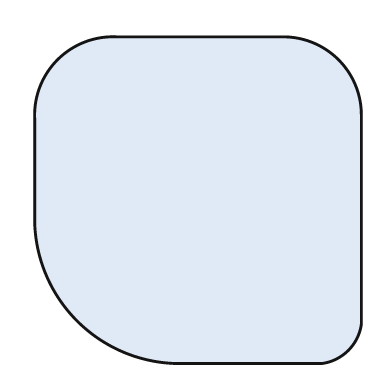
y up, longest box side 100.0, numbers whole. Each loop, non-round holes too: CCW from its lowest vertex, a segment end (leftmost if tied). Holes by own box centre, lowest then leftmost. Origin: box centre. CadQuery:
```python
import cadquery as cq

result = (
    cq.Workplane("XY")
    .moveTo(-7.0, -50.0)
    .lineTo(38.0, -50.0)
    .threePointArc((46.0, -46.0), (50.0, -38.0))
    .lineTo(50.0, 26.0)
    .threePointArc((43.0, 43.0), (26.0, 50.0))
    .lineTo(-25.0, 50.0)
    .threePointArc((-43.0, 43.0), (-50.0, 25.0))
    .lineTo(-50.0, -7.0)
    .threePointArc((-37.0, -37.0), (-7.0, -50.0))
    .close()
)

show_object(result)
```